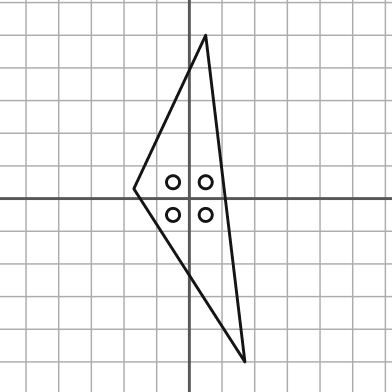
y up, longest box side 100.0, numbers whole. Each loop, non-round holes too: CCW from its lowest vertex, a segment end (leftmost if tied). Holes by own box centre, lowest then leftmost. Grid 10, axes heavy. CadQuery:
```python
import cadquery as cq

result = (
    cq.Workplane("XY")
    .moveTo(17.0, -50.0)
    .lineTo(5.0, 50.0)
    .lineTo(-17.0, 3.0)
    .close()
    .moveTo(-5.0, -5.0)
    .circle(2.0)
    .moveTo(5.0, -5.0)
    .circle(2.0)
    .moveTo(-5.0, 5.0)
    .circle(2.0)
    .moveTo(5.0, 5.0)
    .circle(2.0)
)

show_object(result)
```